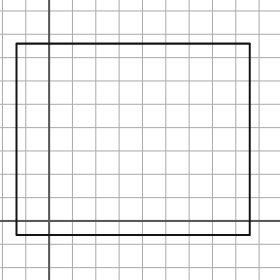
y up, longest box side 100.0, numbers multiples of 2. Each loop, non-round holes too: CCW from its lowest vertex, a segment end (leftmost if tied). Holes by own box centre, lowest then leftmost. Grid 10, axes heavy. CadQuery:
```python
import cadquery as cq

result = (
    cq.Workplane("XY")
    .moveTo(-14.0, -6.0)
    .lineTo(86.0, -6.0)
    .lineTo(86.0, 76.0)
    .lineTo(-14.0, 76.0)
    .close()
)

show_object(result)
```